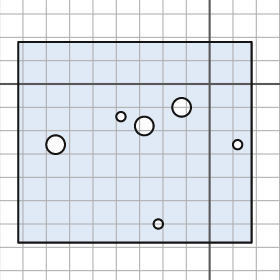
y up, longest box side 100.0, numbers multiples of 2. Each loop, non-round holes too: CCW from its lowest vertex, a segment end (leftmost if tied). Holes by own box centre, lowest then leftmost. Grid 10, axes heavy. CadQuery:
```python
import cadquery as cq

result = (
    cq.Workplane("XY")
    .moveTo(-82.0, -68.0)
    .lineTo(18.0, -68.0)
    .lineTo(18.0, 18.0)
    .lineTo(-82.0, 18.0)
    .close()
    .moveTo(-22.0, -60.0)
    .circle(2.0)
    .moveTo(-66.0, -26.0)
    .circle(4.0)
    .moveTo(12.0, -26.0)
    .circle(2.0)
    .moveTo(-28.0, -18.0)
    .circle(4.0)
    .moveTo(-38.0, -14.0)
    .circle(2.0)
    .moveTo(-12.0, -10.0)
    .circle(4.0)
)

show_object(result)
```